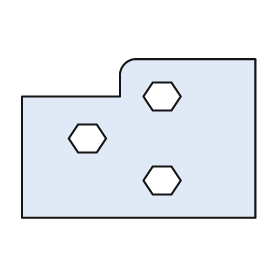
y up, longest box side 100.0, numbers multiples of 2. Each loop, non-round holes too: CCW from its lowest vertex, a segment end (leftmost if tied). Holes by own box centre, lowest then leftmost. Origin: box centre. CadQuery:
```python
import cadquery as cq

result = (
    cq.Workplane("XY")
    .moveTo(-50.0, -34.0)
    .lineTo(50.0, -34.0)
    .lineTo(50.0, 34.0)
    .lineTo(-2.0, 34.0)
    .threePointArc((-6.0, 32.0), (-8.0, 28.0))
    .lineTo(-8.0, 18.0)
    .lineTo(-50.0, 18.0)
    .close()
    .moveTo(6.0, -24.0)
    .lineTo(14.0, -24.0)
    .lineTo(18.0, -18.0)
    .lineTo(14.0, -12.0)
    .lineTo(6.0, -12.0)
    .lineTo(2.0, -18.0)
    .close()
    .moveTo(-26.0, -6.0)
    .lineTo(-18.0, -6.0)
    .lineTo(-14.0, 0.0)
    .lineTo(-18.0, 6.0)
    .lineTo(-26.0, 6.0)
    .lineTo(-30.0, 0.0)
    .close()
    .moveTo(6.0, 12.0)
    .lineTo(14.0, 12.0)
    .lineTo(18.0, 18.0)
    .lineTo(14.0, 24.0)
    .lineTo(6.0, 24.0)
    .lineTo(2.0, 18.0)
    .close()
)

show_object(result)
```